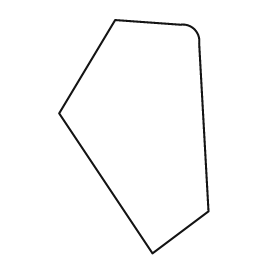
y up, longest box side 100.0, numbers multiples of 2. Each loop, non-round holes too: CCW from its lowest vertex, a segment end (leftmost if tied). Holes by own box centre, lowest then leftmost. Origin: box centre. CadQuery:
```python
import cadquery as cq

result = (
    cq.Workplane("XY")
    .moveTo(8.0, -50.0)
    .lineTo(32.0, -32.0)
    .lineTo(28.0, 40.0)
    .threePointArc((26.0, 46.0), (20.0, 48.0))
    .lineTo(-8.0, 50.0)
    .lineTo(-32.0, 10.0)
    .close()
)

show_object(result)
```